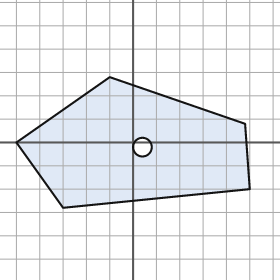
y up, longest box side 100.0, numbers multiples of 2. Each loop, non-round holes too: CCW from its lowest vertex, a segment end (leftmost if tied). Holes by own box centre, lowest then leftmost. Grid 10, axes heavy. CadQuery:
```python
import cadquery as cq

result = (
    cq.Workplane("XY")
    .moveTo(-30.0, -28.0)
    .lineTo(50.0, -20.0)
    .lineTo(48.0, 8.0)
    .lineTo(-10.0, 28.0)
    .lineTo(-50.0, 0.0)
    .close()
    .moveTo(4.0, -2.0)
    .circle(4.0)
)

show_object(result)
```